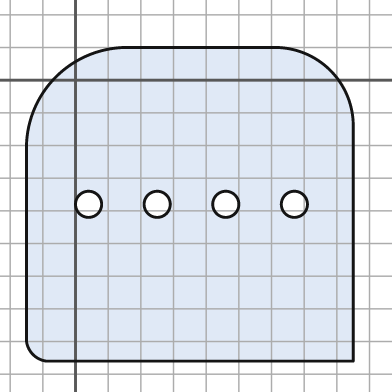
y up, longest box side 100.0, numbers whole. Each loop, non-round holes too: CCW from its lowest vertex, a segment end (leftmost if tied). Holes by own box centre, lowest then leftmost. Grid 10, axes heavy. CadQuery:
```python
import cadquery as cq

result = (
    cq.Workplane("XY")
    .moveTo(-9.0, -86.0)
    .lineTo(85.0, -86.0)
    .lineTo(85.0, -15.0)
    .threePointArc((78.0, 3.0), (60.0, 10.0))
    .lineTo(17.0, 10.0)
    .threePointArc((-6.0, 1.0), (-15.0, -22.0))
    .lineTo(-15.0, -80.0)
    .threePointArc((-13.0, -84.0), (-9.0, -86.0))
    .close()
    .moveTo(4.0, -38.0)
    .circle(4.0)
    .moveTo(25.0, -38.0)
    .circle(4.0)
    .moveTo(46.0, -38.0)
    .circle(4.0)
    .moveTo(67.0, -38.0)
    .circle(4.0)
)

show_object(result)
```